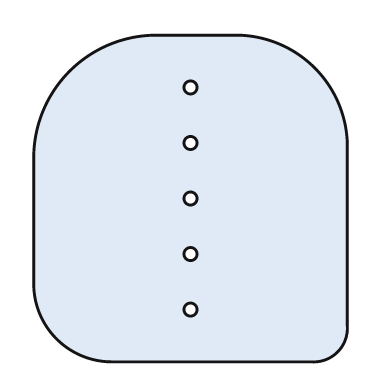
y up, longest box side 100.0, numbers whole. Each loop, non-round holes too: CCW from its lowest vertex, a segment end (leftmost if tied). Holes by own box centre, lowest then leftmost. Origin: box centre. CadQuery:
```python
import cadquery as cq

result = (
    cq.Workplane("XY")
    .moveTo(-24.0, -50.0)
    .lineTo(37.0, -50.0)
    .threePointArc((45.0, -47.0), (48.0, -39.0))
    .lineTo(48.0, 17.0)
    .threePointArc((38.0, 40.0), (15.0, 50.0))
    .lineTo(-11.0, 50.0)
    .threePointArc((-37.0, 39.0), (-48.0, 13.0))
    .lineTo(-48.0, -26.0)
    .threePointArc((-41.0, -43.0), (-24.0, -50.0))
    .close()
    .moveTo(0.0, -34.0)
    .circle(2.0)
    .moveTo(0.0, -17.0)
    .circle(2.0)
    .moveTo(0.0, 0.0)
    .circle(2.0)
    .moveTo(0.0, 17.0)
    .circle(2.0)
    .moveTo(0.0, 34.0)
    .circle(2.0)
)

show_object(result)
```